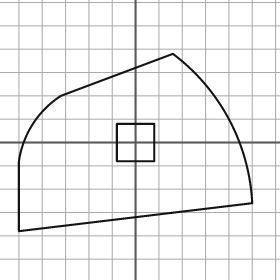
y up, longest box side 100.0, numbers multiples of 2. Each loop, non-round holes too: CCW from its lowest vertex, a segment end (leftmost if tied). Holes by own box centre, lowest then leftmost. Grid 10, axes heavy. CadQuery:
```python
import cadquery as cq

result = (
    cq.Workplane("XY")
    .moveTo(-50.0, -38.0)
    .lineTo(50.0, -26.0)
    .threePointArc((40.0, 10.0), (16.0, 38.0))
    .lineTo(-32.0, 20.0)
    .threePointArc((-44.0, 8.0), (-50.0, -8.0))
    .close()
    .moveTo(-8.0, -8.0)
    .lineTo(8.0, -8.0)
    .lineTo(8.0, 8.0)
    .lineTo(-8.0, 8.0)
    .close()
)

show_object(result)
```